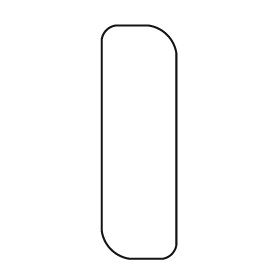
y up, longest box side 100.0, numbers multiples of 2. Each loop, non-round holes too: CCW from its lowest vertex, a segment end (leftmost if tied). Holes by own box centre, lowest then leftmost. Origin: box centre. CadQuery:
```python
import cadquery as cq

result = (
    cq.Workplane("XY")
    .moveTo(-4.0, -50.0)
    .lineTo(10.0, -50.0)
    .threePointArc((14.0, -48.0), (16.0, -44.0))
    .lineTo(16.0, 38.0)
    .threePointArc((12.0, 46.0), (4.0, 50.0))
    .lineTo(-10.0, 50.0)
    .threePointArc((-14.0, 48.0), (-16.0, 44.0))
    .lineTo(-16.0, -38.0)
    .threePointArc((-12.0, -46.0), (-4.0, -50.0))
    .close()
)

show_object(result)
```